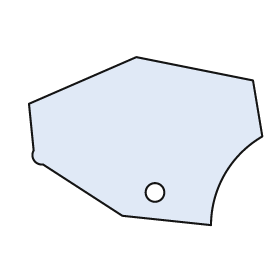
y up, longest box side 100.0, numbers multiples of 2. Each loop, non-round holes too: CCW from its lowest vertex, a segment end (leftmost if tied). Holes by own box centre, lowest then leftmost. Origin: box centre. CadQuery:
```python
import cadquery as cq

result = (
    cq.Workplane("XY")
    .moveTo(28.0, -36.0)
    .threePointArc((34.0, -14.0), (50.0, 2.0))
    .lineTo(46.0, 26.0)
    .lineTo(-4.0, 36.0)
    .lineTo(-50.0, 16.0)
    .lineTo(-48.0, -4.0)
    .threePointArc((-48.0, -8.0), (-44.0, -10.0))
    .lineTo(-10.0, -32.0)
    .close()
    .moveTo(4.0, -22.0)
    .circle(4.0)
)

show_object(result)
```